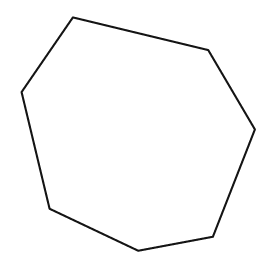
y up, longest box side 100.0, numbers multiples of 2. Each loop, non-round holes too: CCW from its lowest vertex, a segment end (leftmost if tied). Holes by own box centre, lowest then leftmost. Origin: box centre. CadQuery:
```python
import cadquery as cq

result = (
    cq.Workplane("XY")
    .moveTo(0.0, -50.0)
    .lineTo(32.0, -44.0)
    .lineTo(50.0, 2.0)
    .lineTo(30.0, 36.0)
    .lineTo(-28.0, 50.0)
    .lineTo(-50.0, 18.0)
    .lineTo(-38.0, -32.0)
    .close()
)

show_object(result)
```